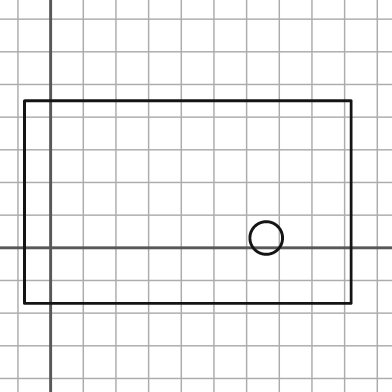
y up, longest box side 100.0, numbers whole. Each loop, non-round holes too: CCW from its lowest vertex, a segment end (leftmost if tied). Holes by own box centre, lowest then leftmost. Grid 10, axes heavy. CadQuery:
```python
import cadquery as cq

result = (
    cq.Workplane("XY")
    .moveTo(-8.0, -17.0)
    .lineTo(92.0, -17.0)
    .lineTo(92.0, 45.0)
    .lineTo(-8.0, 45.0)
    .close()
    .moveTo(66.0, 3.0)
    .circle(5.0)
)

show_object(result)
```